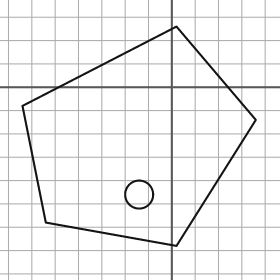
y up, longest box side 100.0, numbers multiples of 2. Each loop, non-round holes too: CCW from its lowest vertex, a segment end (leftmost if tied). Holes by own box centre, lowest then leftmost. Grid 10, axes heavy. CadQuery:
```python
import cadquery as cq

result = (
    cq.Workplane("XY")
    .moveTo(2.0, -68.0)
    .lineTo(36.0, -14.0)
    .lineTo(2.0, 26.0)
    .lineTo(-64.0, -8.0)
    .lineTo(-54.0, -58.0)
    .close()
    .moveTo(-14.0, -46.0)
    .circle(6.0)
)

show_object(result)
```